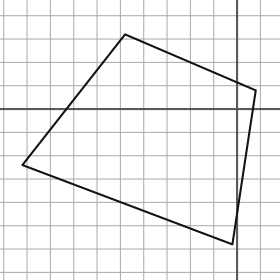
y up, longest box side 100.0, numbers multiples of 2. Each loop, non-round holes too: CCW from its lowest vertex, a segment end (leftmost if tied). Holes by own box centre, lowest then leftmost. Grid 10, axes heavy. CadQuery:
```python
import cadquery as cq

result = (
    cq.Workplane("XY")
    .moveTo(-2.0, -58.0)
    .lineTo(8.0, 8.0)
    .lineTo(-48.0, 32.0)
    .lineTo(-92.0, -24.0)
    .close()
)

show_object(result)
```